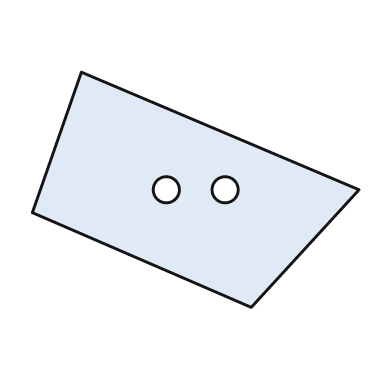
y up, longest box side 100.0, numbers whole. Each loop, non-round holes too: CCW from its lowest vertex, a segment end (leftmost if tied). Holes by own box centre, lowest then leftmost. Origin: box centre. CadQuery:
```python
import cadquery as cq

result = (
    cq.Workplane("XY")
    .moveTo(17.0, -36.0)
    .lineTo(50.0, 0.0)
    .lineTo(-35.0, 36.0)
    .lineTo(-50.0, -7.0)
    .close()
    .moveTo(-9.0, 0.0)
    .circle(4.0)
    .moveTo(9.0, 0.0)
    .circle(4.0)
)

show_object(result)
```